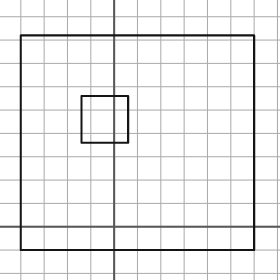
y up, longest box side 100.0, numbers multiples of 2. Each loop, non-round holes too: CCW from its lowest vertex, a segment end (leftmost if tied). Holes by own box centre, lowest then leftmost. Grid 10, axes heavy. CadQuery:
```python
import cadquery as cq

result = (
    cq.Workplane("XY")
    .moveTo(-40.0, -10.0)
    .lineTo(60.0, -10.0)
    .lineTo(60.0, 82.0)
    .lineTo(-40.0, 82.0)
    .close()
    .moveTo(-14.0, 36.0)
    .lineTo(6.0, 36.0)
    .lineTo(6.0, 56.0)
    .lineTo(-14.0, 56.0)
    .close()
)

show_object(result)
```